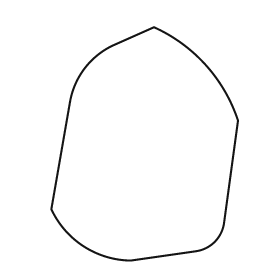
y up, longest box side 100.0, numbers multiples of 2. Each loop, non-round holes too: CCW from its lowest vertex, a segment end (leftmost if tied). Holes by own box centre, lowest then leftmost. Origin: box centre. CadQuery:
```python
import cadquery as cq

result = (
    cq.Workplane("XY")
    .moveTo(-6.0, -50.0)
    .lineTo(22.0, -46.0)
    .threePointArc((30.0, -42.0), (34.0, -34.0))
    .lineTo(40.0, 10.0)
    .threePointArc((26.0, 34.0), (4.0, 50.0))
    .lineTo(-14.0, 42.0)
    .threePointArc((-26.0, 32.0), (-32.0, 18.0))
    .lineTo(-40.0, -28.0)
    .threePointArc((-26.0, -44.0), (-6.0, -50.0))
    .close()
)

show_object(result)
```